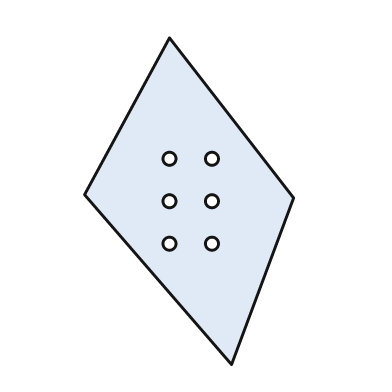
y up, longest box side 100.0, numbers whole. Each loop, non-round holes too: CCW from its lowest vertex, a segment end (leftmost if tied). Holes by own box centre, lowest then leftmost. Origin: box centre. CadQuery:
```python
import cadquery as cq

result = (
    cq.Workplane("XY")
    .moveTo(13.0, -50.0)
    .lineTo(32.0, 1.0)
    .lineTo(-6.0, 50.0)
    .lineTo(-32.0, 2.0)
    .close()
    .moveTo(-6.0, -13.0)
    .circle(2.0)
    .moveTo(7.0, -13.0)
    .circle(2.0)
    .moveTo(-6.0, 0.0)
    .circle(2.0)
    .moveTo(7.0, 0.0)
    .circle(2.0)
    .moveTo(-6.0, 13.0)
    .circle(2.0)
    .moveTo(7.0, 13.0)
    .circle(2.0)
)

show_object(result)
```